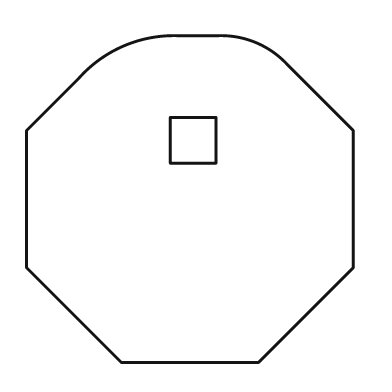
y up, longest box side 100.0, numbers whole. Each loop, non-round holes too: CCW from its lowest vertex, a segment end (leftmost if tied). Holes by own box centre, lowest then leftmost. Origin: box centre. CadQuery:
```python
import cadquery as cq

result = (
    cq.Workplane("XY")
    .moveTo(-21.0, -50.0)
    .lineTo(21.0, -50.0)
    .lineTo(50.0, -21.0)
    .lineTo(50.0, 21.0)
    .lineTo(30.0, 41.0)
    .threePointArc((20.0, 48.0), (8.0, 50.0))
    .lineTo(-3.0, 50.0)
    .threePointArc((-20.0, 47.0), (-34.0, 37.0))
    .lineTo(-50.0, 21.0)
    .lineTo(-50.0, -21.0)
    .close()
    .moveTo(-6.0, 11.0)
    .lineTo(8.0, 11.0)
    .lineTo(8.0, 25.0)
    .lineTo(-6.0, 25.0)
    .close()
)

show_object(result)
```